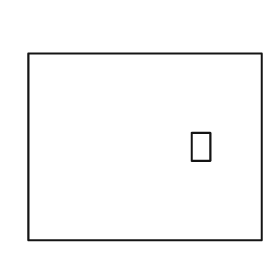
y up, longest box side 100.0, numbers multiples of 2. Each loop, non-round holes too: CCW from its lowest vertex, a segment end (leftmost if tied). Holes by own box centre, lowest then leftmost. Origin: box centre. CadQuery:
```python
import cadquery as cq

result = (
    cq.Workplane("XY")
    .moveTo(-50.0, -40.0)
    .lineTo(50.0, -40.0)
    .lineTo(50.0, 40.0)
    .lineTo(-50.0, 40.0)
    .close()
    .moveTo(20.0, -6.0)
    .lineTo(28.0, -6.0)
    .lineTo(28.0, 6.0)
    .lineTo(20.0, 6.0)
    .close()
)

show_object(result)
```